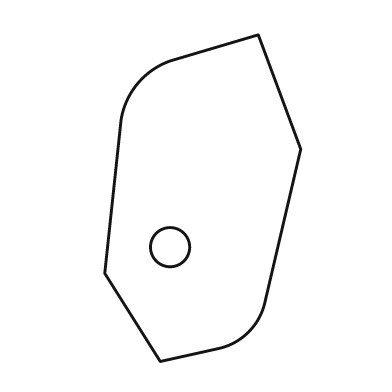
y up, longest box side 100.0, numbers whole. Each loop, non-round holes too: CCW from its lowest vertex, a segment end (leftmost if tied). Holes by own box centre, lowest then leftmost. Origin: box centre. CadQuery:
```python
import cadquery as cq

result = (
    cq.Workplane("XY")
    .moveTo(-13.0, -50.0)
    .lineTo(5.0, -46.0)
    .threePointArc((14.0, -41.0), (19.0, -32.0))
    .lineTo(30.0, 15.0)
    .lineTo(17.0, 50.0)
    .lineTo(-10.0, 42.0)
    .threePointArc((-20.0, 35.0), (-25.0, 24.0))
    .lineTo(-30.0, -23.0)
    .close()
    .moveTo(-10.0, -15.0)
    .circle(6.0)
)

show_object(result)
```